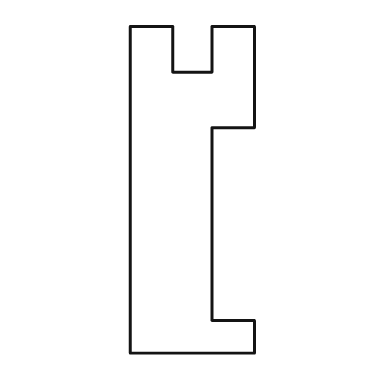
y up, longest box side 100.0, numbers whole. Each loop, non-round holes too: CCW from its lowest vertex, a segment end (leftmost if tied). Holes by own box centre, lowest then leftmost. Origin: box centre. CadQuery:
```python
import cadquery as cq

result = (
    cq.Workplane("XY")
    .moveTo(-19.0, -50.0)
    .lineTo(19.0, -50.0)
    .lineTo(19.0, -40.0)
    .lineTo(6.0, -40.0)
    .lineTo(6.0, 19.0)
    .lineTo(19.0, 19.0)
    .lineTo(19.0, 50.0)
    .lineTo(6.0, 50.0)
    .lineTo(6.0, 36.0)
    .lineTo(-6.0, 36.0)
    .lineTo(-6.0, 50.0)
    .lineTo(-19.0, 50.0)
    .close()
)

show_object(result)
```